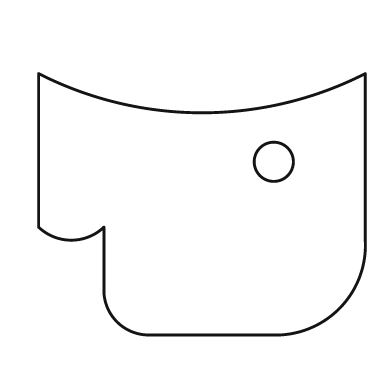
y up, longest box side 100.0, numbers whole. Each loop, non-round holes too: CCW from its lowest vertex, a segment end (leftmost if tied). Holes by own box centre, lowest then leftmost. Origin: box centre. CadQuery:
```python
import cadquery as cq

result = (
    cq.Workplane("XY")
    .moveTo(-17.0, -40.0)
    .lineTo(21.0, -40.0)
    .threePointArc((42.0, -32.0), (50.0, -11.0))
    .lineTo(50.0, 40.0)
    .threePointArc((0.0, 28.0), (-50.0, 40.0))
    .lineTo(-50.0, -7.0)
    .threePointArc((-40.0, -11.0), (-30.0, -7.0))
    .lineTo(-30.0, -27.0)
    .threePointArc((-26.0, -36.0), (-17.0, -40.0))
    .close()
    .moveTo(22.0, 13.0)
    .circle(6.0)
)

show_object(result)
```